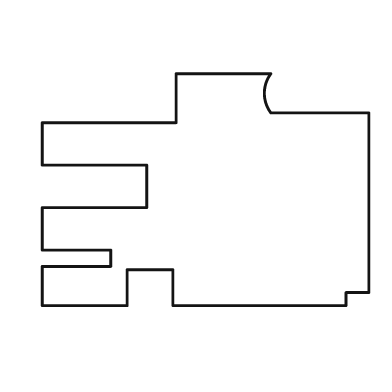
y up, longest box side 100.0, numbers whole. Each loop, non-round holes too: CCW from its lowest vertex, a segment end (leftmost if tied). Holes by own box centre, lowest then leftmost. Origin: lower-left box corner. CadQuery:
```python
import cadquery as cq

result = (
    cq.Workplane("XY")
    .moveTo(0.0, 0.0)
    .lineTo(26.0, 0.0)
    .lineTo(26.0, 11.0)
    .lineTo(40.0, 11.0)
    .lineTo(40.0, 0.0)
    .lineTo(93.0, 0.0)
    .lineTo(93.0, 4.0)
    .lineTo(100.0, 4.0)
    .lineTo(100.0, 59.0)
    .lineTo(70.0, 59.0)
    .threePointArc((68.0, 65.0), (70.0, 71.0))
    .lineTo(41.0, 71.0)
    .lineTo(41.0, 56.0)
    .lineTo(0.0, 56.0)
    .lineTo(0.0, 43.0)
    .lineTo(32.0, 43.0)
    .lineTo(32.0, 30.0)
    .lineTo(0.0, 30.0)
    .lineTo(0.0, 17.0)
    .lineTo(21.0, 17.0)
    .lineTo(21.0, 12.0)
    .lineTo(0.0, 12.0)
    .close()
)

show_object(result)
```